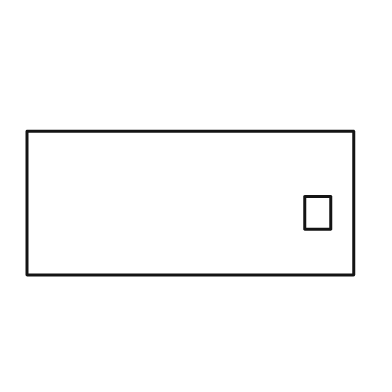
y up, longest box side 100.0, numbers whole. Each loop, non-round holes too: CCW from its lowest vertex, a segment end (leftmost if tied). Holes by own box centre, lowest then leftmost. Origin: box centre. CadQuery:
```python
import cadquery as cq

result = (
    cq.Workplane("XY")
    .moveTo(-50.0, -22.0)
    .lineTo(50.0, -22.0)
    .lineTo(50.0, 22.0)
    .lineTo(-50.0, 22.0)
    .close()
    .moveTo(35.0, -8.0)
    .lineTo(43.0, -8.0)
    .lineTo(43.0, 2.0)
    .lineTo(35.0, 2.0)
    .close()
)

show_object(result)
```